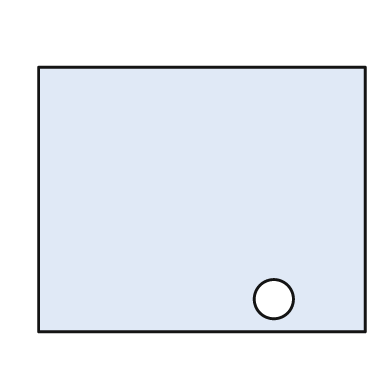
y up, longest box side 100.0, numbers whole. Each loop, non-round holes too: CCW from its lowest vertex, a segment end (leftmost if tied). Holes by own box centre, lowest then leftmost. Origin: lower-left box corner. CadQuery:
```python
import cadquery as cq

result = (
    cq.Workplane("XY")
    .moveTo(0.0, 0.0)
    .lineTo(100.0, 0.0)
    .lineTo(100.0, 81.0)
    .lineTo(0.0, 81.0)
    .close()
    .moveTo(72.0, 10.0)
    .circle(6.0)
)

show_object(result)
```